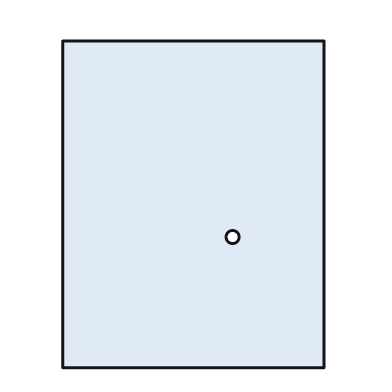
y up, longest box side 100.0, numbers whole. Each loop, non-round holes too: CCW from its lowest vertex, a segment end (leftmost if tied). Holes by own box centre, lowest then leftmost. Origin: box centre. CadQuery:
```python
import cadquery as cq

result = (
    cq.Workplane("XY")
    .moveTo(-40.0, -50.0)
    .lineTo(40.0, -50.0)
    .lineTo(40.0, 50.0)
    .lineTo(-40.0, 50.0)
    .close()
    .moveTo(12.0, -10.0)
    .circle(2.0)
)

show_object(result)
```